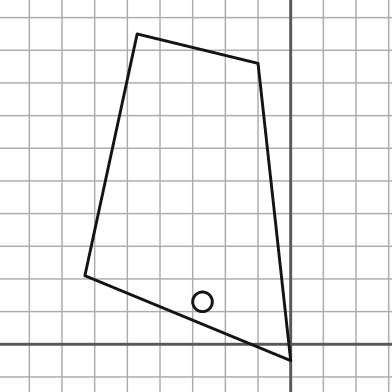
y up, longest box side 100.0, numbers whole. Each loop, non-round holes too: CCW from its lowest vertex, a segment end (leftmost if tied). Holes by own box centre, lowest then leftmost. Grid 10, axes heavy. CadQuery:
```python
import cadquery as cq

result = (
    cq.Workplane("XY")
    .moveTo(0.0, -5.0)
    .lineTo(-10.0, 86.0)
    .lineTo(-47.0, 95.0)
    .lineTo(-63.0, 21.0)
    .close()
    .moveTo(-27.0, 13.0)
    .circle(3.0)
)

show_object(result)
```